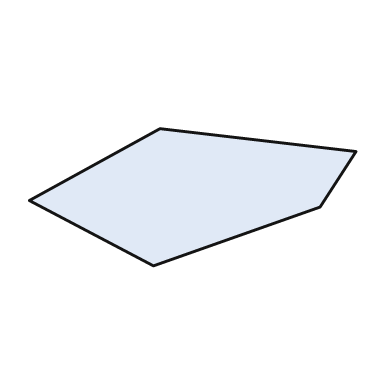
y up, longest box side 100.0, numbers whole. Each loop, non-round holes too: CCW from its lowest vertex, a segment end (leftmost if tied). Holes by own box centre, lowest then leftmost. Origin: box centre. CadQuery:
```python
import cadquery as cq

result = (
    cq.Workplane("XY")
    .moveTo(-12.0, -21.0)
    .lineTo(39.0, -3.0)
    .lineTo(50.0, 14.0)
    .lineTo(-10.0, 21.0)
    .lineTo(-50.0, -1.0)
    .close()
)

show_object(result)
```